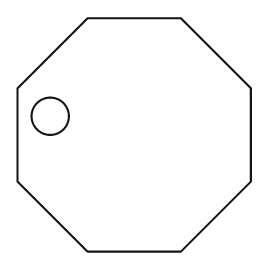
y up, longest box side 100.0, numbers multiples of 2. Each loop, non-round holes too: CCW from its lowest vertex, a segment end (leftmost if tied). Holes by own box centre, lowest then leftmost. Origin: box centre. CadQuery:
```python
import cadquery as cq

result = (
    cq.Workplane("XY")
    .moveTo(-20.0, -50.0)
    .lineTo(20.0, -50.0)
    .lineTo(50.0, -20.0)
    .lineTo(50.0, 20.0)
    .lineTo(20.0, 50.0)
    .lineTo(-20.0, 50.0)
    .lineTo(-50.0, 20.0)
    .lineTo(-50.0, -20.0)
    .close()
    .moveTo(-36.0, 8.0)
    .circle(8.0)
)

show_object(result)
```